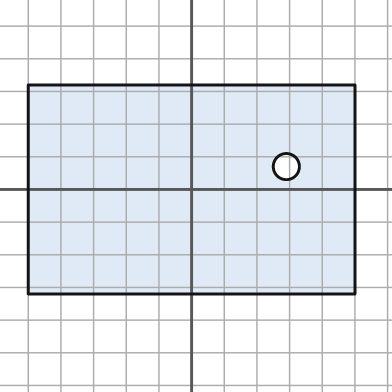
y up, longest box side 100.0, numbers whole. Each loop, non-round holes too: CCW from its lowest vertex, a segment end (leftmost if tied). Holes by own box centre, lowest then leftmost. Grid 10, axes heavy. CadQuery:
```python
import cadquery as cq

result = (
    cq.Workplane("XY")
    .moveTo(-50.0, -32.0)
    .lineTo(50.0, -32.0)
    .lineTo(50.0, 32.0)
    .lineTo(-50.0, 32.0)
    .close()
    .moveTo(29.0, 7.0)
    .circle(4.0)
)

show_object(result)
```